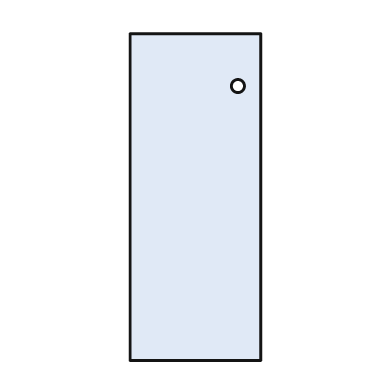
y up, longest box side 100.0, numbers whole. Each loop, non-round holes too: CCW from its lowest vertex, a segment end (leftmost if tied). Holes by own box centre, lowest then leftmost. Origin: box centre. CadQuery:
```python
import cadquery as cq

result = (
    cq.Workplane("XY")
    .moveTo(-20.0, -50.0)
    .lineTo(20.0, -50.0)
    .lineTo(20.0, 50.0)
    .lineTo(-20.0, 50.0)
    .close()
    .moveTo(13.0, 34.0)
    .circle(2.0)
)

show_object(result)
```